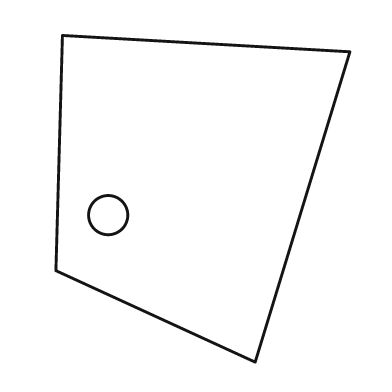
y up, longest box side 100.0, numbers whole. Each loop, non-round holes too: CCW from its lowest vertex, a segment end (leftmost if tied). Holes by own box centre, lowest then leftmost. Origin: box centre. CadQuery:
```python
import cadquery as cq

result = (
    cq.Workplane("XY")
    .moveTo(16.0, -50.0)
    .lineTo(45.0, 45.0)
    .lineTo(-43.0, 50.0)
    .lineTo(-45.0, -22.0)
    .close()
    .moveTo(-29.0, -5.0)
    .circle(6.0)
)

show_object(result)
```